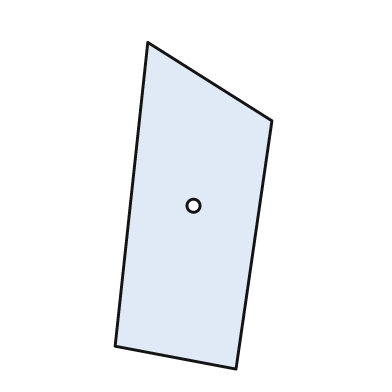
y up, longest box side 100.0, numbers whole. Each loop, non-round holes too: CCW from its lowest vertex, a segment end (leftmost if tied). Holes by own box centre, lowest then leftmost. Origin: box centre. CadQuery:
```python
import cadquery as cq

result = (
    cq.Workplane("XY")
    .moveTo(13.0, -50.0)
    .lineTo(24.0, 26.0)
    .lineTo(-14.0, 50.0)
    .lineTo(-24.0, -43.0)
    .close()
    .moveTo(0.0, 0.0)
    .circle(2.0)
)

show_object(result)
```